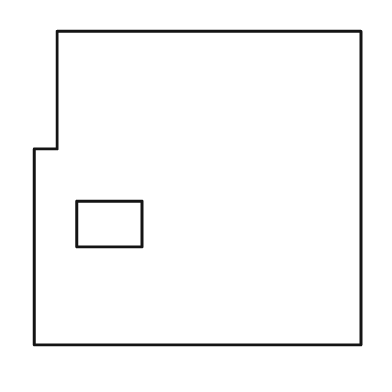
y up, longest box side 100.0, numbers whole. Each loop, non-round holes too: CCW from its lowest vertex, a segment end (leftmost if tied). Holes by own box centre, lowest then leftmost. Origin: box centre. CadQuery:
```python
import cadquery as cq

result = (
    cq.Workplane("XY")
    .moveTo(-50.0, -48.0)
    .lineTo(50.0, -48.0)
    .lineTo(50.0, 48.0)
    .lineTo(-43.0, 48.0)
    .lineTo(-43.0, 12.0)
    .lineTo(-50.0, 12.0)
    .close()
    .moveTo(-37.0, -18.0)
    .lineTo(-17.0, -18.0)
    .lineTo(-17.0, -4.0)
    .lineTo(-37.0, -4.0)
    .close()
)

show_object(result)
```